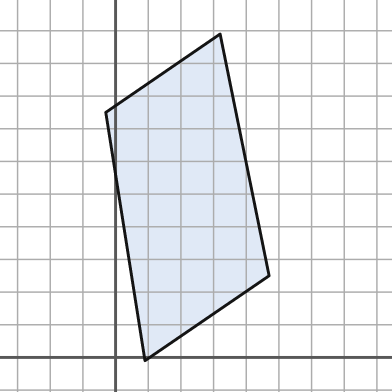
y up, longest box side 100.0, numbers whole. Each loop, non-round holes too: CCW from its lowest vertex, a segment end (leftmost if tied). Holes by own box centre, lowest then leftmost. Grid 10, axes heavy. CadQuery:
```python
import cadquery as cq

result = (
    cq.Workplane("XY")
    .moveTo(9.0, -1.0)
    .lineTo(47.0, 25.0)
    .lineTo(32.0, 99.0)
    .lineTo(-3.0, 75.0)
    .close()
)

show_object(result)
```